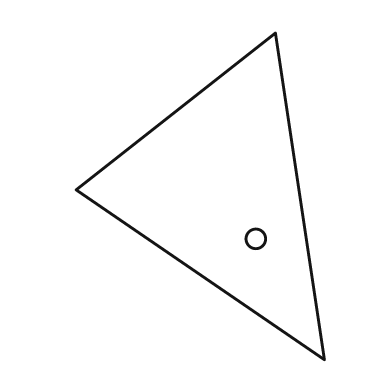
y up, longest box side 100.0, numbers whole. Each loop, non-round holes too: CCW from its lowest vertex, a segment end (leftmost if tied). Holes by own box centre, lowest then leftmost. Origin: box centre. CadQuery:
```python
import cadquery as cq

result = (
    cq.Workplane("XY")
    .moveTo(38.0, -50.0)
    .lineTo(23.0, 50.0)
    .lineTo(-38.0, 2.0)
    .close()
    .moveTo(17.0, -13.0)
    .circle(3.0)
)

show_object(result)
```